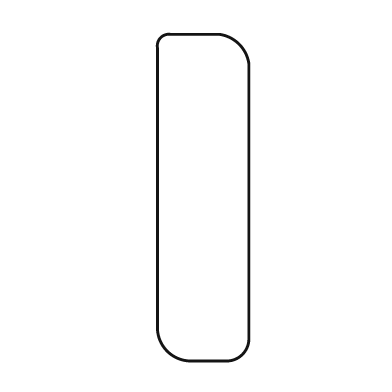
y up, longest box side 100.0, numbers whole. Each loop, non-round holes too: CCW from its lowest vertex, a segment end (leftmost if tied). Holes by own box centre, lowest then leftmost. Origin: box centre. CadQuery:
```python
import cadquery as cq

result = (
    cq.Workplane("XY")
    .moveTo(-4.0, -50.0)
    .lineTo(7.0, -50.0)
    .threePointArc((12.0, -48.0), (14.0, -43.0))
    .lineTo(14.0, 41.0)
    .threePointArc((11.0, 47.0), (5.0, 50.0))
    .lineTo(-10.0, 50.0)
    .threePointArc((-13.0, 49.0), (-14.0, 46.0))
    .lineTo(-14.0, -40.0)
    .threePointArc((-11.0, -47.0), (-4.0, -50.0))
    .close()
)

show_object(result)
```